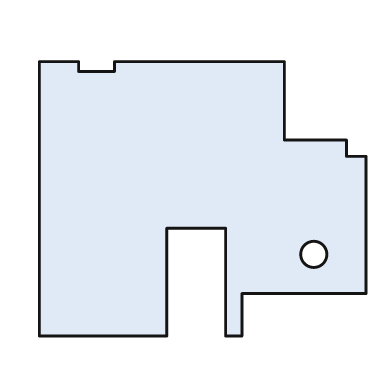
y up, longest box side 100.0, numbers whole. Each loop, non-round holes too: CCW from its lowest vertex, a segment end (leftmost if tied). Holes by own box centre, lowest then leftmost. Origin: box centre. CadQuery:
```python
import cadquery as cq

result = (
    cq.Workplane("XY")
    .moveTo(-50.0, -42.0)
    .lineTo(-11.0, -42.0)
    .lineTo(-11.0, -9.0)
    .lineTo(7.0, -9.0)
    .lineTo(7.0, -42.0)
    .lineTo(12.0, -42.0)
    .lineTo(12.0, -29.0)
    .lineTo(50.0, -29.0)
    .lineTo(50.0, 13.0)
    .lineTo(44.0, 13.0)
    .lineTo(44.0, 18.0)
    .lineTo(25.0, 18.0)
    .lineTo(25.0, 42.0)
    .lineTo(-27.0, 42.0)
    .lineTo(-27.0, 39.0)
    .lineTo(-38.0, 39.0)
    .lineTo(-38.0, 42.0)
    .lineTo(-50.0, 42.0)
    .close()
    .moveTo(34.0, -17.0)
    .circle(4.0)
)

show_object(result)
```